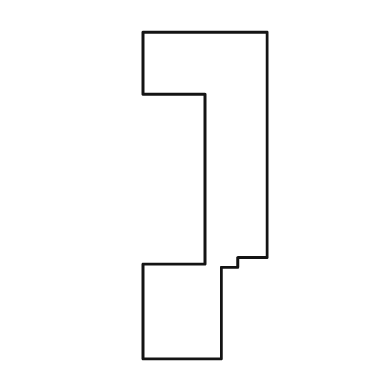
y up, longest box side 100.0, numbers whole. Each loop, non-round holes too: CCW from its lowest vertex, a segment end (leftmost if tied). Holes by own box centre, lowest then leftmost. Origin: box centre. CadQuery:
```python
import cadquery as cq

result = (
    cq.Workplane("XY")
    .moveTo(-19.0, -50.0)
    .lineTo(5.0, -50.0)
    .lineTo(5.0, -22.0)
    .lineTo(10.0, -22.0)
    .lineTo(10.0, -19.0)
    .lineTo(19.0, -19.0)
    .lineTo(19.0, 50.0)
    .lineTo(-19.0, 50.0)
    .lineTo(-19.0, 31.0)
    .lineTo(0.0, 31.0)
    .lineTo(0.0, -21.0)
    .lineTo(-19.0, -21.0)
    .close()
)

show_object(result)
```